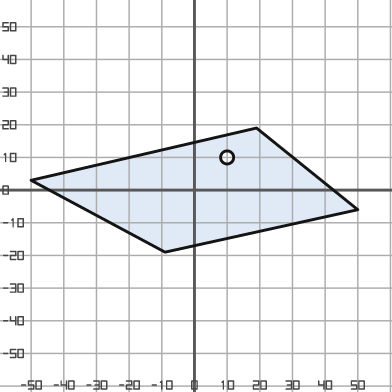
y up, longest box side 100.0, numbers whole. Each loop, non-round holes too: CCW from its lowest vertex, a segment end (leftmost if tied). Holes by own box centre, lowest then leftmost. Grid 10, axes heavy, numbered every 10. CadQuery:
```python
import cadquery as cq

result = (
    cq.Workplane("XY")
    .moveTo(-9.0, -19.0)
    .lineTo(50.0, -6.0)
    .lineTo(19.0, 19.0)
    .lineTo(-50.0, 3.0)
    .close()
    .moveTo(10.0, 10.0)
    .circle(2.0)
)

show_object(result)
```